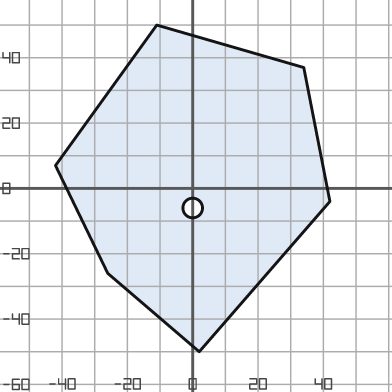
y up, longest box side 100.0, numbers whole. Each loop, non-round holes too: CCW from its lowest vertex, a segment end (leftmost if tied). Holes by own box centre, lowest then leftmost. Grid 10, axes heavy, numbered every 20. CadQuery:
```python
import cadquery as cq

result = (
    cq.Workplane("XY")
    .moveTo(2.0, -50.0)
    .lineTo(42.0, -4.0)
    .lineTo(34.0, 37.0)
    .lineTo(-11.0, 50.0)
    .lineTo(-42.0, 7.0)
    .lineTo(-26.0, -26.0)
    .close()
    .moveTo(0.0, -6.0)
    .circle(3.0)
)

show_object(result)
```